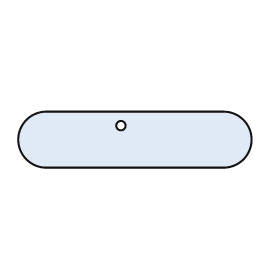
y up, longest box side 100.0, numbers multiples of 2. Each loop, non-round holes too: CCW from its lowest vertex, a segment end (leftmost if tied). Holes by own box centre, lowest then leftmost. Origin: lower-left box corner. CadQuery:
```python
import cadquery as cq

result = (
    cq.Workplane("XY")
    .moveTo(12.0, 0.0)
    .lineTo(88.0, 0.0)
    .threePointArc((100.0, 12.0), (88.0, 24.0))
    .lineTo(12.0, 24.0)
    .threePointArc((0.0, 12.0), (12.0, 0.0))
    .close()
    .moveTo(44.0, 18.0)
    .circle(2.0)
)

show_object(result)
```